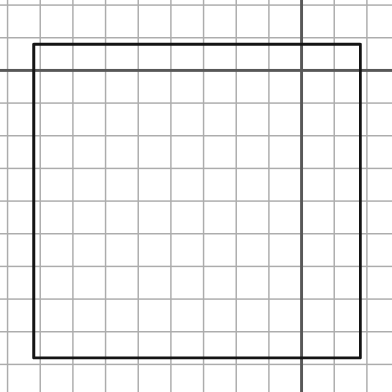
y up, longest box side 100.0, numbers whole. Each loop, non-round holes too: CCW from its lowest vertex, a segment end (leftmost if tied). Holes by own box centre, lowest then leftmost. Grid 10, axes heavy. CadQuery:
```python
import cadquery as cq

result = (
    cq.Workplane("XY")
    .moveTo(-82.0, -88.0)
    .lineTo(18.0, -88.0)
    .lineTo(18.0, 8.0)
    .lineTo(-82.0, 8.0)
    .close()
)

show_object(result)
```